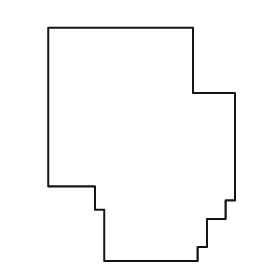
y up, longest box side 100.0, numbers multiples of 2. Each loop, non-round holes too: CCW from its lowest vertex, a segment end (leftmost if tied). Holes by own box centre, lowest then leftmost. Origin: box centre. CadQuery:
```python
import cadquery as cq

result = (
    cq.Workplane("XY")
    .moveTo(-16.0, -50.0)
    .lineTo(24.0, -50.0)
    .lineTo(24.0, -44.0)
    .lineTo(28.0, -44.0)
    .lineTo(28.0, -32.0)
    .lineTo(36.0, -32.0)
    .lineTo(36.0, -24.0)
    .lineTo(40.0, -24.0)
    .lineTo(40.0, 22.0)
    .lineTo(22.0, 22.0)
    .lineTo(22.0, 50.0)
    .lineTo(-40.0, 50.0)
    .lineTo(-40.0, -18.0)
    .lineTo(-20.0, -18.0)
    .lineTo(-20.0, -28.0)
    .lineTo(-16.0, -28.0)
    .close()
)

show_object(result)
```